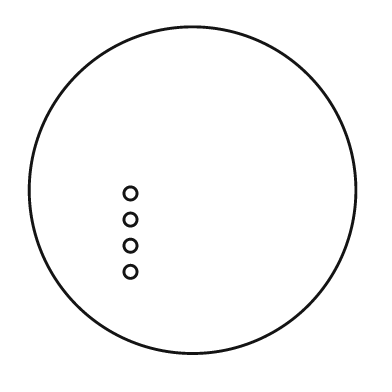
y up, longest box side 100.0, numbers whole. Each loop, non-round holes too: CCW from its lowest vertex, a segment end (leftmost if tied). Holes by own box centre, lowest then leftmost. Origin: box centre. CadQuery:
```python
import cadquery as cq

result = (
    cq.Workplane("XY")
    .moveTo(0.0, 0.0)
    .circle(50.0)
    .moveTo(-19.0, -25.0)
    .circle(2.0)
    .moveTo(-19.0, -17.0)
    .circle(2.0)
    .moveTo(-19.0, -9.0)
    .circle(2.0)
    .moveTo(-19.0, -1.0)
    .circle(2.0)
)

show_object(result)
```